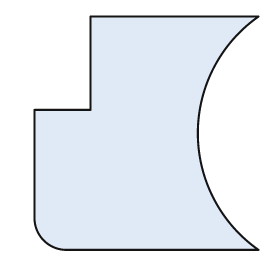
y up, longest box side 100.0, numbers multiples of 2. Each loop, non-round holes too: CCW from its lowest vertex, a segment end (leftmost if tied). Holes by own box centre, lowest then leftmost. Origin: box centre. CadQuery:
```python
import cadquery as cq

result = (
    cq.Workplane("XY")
    .moveTo(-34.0, -50.0)
    .lineTo(48.0, -50.0)
    .threePointArc((22.0, 0.0), (48.0, 50.0))
    .lineTo(-24.0, 50.0)
    .lineTo(-24.0, 10.0)
    .lineTo(-48.0, 10.0)
    .lineTo(-48.0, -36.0)
    .threePointArc((-44.0, -46.0), (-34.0, -50.0))
    .close()
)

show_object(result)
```